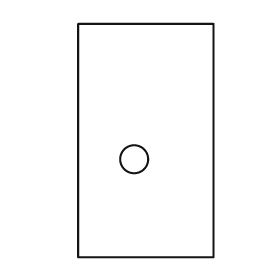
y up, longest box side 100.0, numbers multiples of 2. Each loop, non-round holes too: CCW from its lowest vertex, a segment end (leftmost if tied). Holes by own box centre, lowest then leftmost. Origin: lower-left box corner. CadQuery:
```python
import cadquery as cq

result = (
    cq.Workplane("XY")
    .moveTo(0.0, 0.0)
    .lineTo(58.0, 0.0)
    .lineTo(58.0, 100.0)
    .lineTo(0.0, 100.0)
    .close()
    .moveTo(24.0, 42.0)
    .circle(6.0)
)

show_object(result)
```